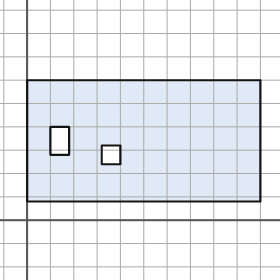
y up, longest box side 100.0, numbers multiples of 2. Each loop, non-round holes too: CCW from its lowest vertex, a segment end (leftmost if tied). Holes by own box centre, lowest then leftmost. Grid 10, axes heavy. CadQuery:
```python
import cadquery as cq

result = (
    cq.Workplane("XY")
    .moveTo(0.0, 8.0)
    .lineTo(100.0, 8.0)
    .lineTo(100.0, 60.0)
    .lineTo(0.0, 60.0)
    .close()
    .moveTo(32.0, 24.0)
    .lineTo(40.0, 24.0)
    .lineTo(40.0, 32.0)
    .lineTo(32.0, 32.0)
    .close()
    .moveTo(10.0, 28.0)
    .lineTo(18.0, 28.0)
    .lineTo(18.0, 40.0)
    .lineTo(10.0, 40.0)
    .close()
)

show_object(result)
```